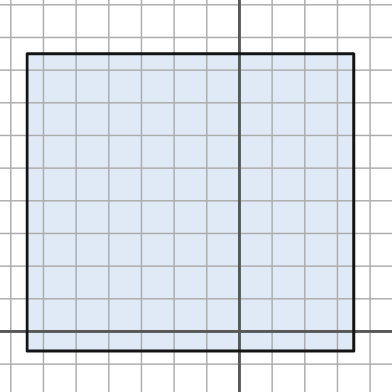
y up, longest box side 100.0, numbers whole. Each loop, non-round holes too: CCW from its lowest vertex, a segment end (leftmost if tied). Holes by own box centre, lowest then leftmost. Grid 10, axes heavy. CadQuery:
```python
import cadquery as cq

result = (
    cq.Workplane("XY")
    .moveTo(-65.0, -6.0)
    .lineTo(35.0, -6.0)
    .lineTo(35.0, 85.0)
    .lineTo(-65.0, 85.0)
    .close()
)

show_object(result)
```